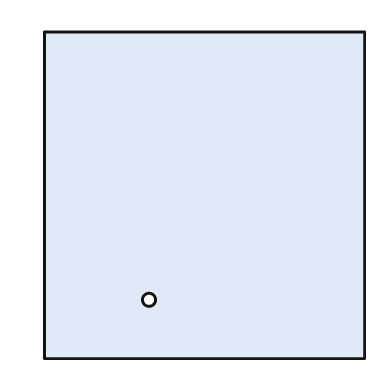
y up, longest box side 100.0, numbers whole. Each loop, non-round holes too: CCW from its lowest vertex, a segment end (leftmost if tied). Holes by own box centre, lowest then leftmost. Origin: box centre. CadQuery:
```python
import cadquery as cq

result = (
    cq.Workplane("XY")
    .moveTo(-49.0, -50.0)
    .lineTo(49.0, -50.0)
    .lineTo(49.0, 50.0)
    .lineTo(-49.0, 50.0)
    .close()
    .moveTo(-17.0, -32.0)
    .circle(2.0)
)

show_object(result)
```